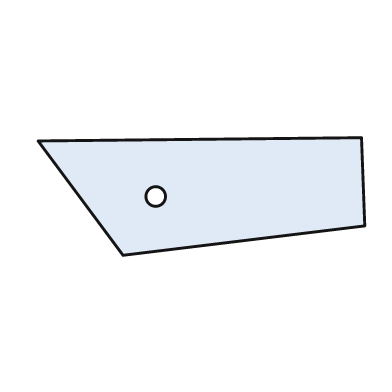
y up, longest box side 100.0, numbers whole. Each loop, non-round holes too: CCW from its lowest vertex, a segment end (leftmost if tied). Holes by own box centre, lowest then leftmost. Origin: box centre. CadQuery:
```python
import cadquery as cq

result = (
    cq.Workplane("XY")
    .moveTo(-24.0, -18.0)
    .lineTo(50.0, -9.0)
    .lineTo(49.0, 18.0)
    .lineTo(-50.0, 17.0)
    .close()
    .moveTo(-14.0, 0.0)
    .circle(3.0)
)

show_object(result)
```